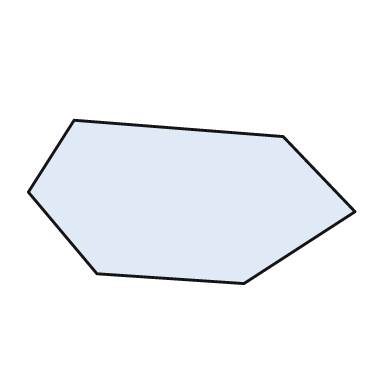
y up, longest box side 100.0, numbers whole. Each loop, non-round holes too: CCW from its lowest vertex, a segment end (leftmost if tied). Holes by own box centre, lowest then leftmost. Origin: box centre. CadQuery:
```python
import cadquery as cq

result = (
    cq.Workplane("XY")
    .moveTo(16.0, -25.0)
    .lineTo(50.0, -3.0)
    .lineTo(28.0, 20.0)
    .lineTo(-36.0, 25.0)
    .lineTo(-50.0, 3.0)
    .lineTo(-29.0, -22.0)
    .close()
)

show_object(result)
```